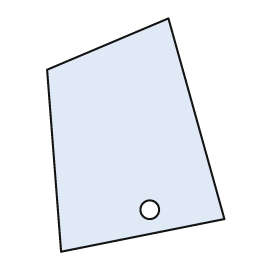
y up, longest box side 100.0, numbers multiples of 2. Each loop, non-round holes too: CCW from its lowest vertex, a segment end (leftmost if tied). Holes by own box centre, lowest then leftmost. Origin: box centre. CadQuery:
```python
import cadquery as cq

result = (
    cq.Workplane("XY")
    .moveTo(-32.0, -50.0)
    .lineTo(38.0, -36.0)
    .lineTo(14.0, 50.0)
    .lineTo(-38.0, 28.0)
    .close()
    .moveTo(6.0, -32.0)
    .circle(4.0)
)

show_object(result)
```